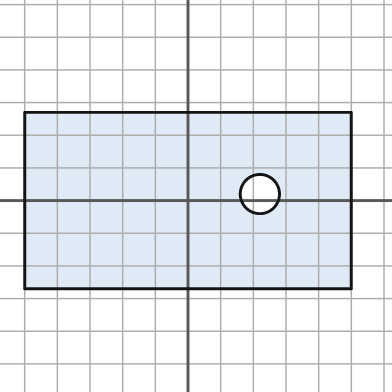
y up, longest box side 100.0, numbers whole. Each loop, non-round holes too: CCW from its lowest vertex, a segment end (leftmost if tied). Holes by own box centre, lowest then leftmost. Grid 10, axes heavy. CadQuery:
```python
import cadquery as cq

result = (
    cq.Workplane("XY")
    .moveTo(-50.0, -27.0)
    .lineTo(50.0, -27.0)
    .lineTo(50.0, 27.0)
    .lineTo(-50.0, 27.0)
    .close()
    .moveTo(22.0, 2.0)
    .circle(6.0)
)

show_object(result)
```